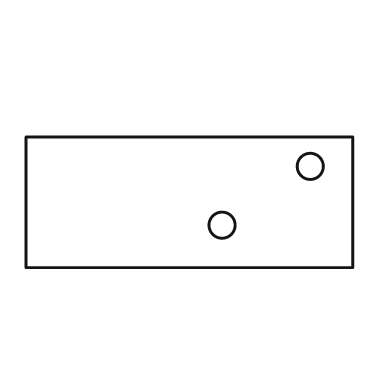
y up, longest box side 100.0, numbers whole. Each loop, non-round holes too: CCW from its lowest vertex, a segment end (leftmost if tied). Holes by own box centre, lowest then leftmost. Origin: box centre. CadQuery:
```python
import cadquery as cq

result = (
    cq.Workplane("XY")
    .moveTo(-50.0, -20.0)
    .lineTo(50.0, -20.0)
    .lineTo(50.0, 20.0)
    .lineTo(-50.0, 20.0)
    .close()
    .moveTo(10.0, -7.0)
    .circle(4.0)
    .moveTo(37.0, 11.0)
    .circle(4.0)
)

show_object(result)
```